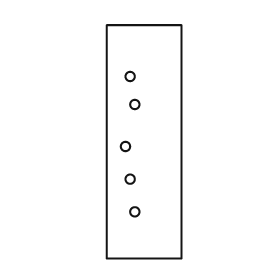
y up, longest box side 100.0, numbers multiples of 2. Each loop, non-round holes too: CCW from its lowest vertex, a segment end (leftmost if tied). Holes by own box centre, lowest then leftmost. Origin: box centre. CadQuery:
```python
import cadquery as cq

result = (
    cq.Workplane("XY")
    .moveTo(-16.0, -50.0)
    .lineTo(16.0, -50.0)
    .lineTo(16.0, 50.0)
    .lineTo(-16.0, 50.0)
    .close()
    .moveTo(-4.0, -30.0)
    .circle(2.0)
    .moveTo(-6.0, -16.0)
    .circle(2.0)
    .moveTo(-8.0, -2.0)
    .circle(2.0)
    .moveTo(-4.0, 16.0)
    .circle(2.0)
    .moveTo(-6.0, 28.0)
    .circle(2.0)
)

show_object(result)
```